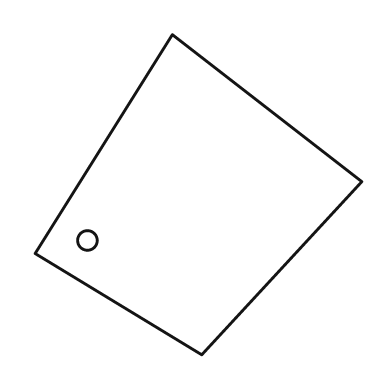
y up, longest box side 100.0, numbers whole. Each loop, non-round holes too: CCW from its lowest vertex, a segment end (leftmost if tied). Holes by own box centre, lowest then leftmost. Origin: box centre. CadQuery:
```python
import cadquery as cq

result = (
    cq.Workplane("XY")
    .moveTo(1.0, -49.0)
    .lineTo(50.0, 4.0)
    .lineTo(-8.0, 49.0)
    .lineTo(-50.0, -18.0)
    .close()
    .moveTo(-34.0, -14.0)
    .circle(3.0)
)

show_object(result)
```